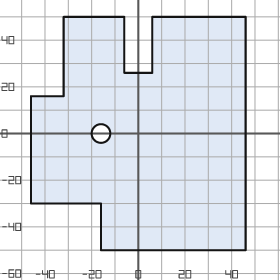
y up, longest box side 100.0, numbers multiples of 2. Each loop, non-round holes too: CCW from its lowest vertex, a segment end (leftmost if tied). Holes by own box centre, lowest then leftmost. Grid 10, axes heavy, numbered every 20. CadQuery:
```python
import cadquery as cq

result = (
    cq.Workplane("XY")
    .moveTo(-16.0, -50.0)
    .lineTo(46.0, -50.0)
    .lineTo(46.0, 50.0)
    .lineTo(6.0, 50.0)
    .lineTo(6.0, 26.0)
    .lineTo(-6.0, 26.0)
    .lineTo(-6.0, 50.0)
    .lineTo(-32.0, 50.0)
    .lineTo(-32.0, 16.0)
    .lineTo(-46.0, 16.0)
    .lineTo(-46.0, -30.0)
    .lineTo(-16.0, -30.0)
    .close()
    .moveTo(-16.0, 0.0)
    .circle(4.0)
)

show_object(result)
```